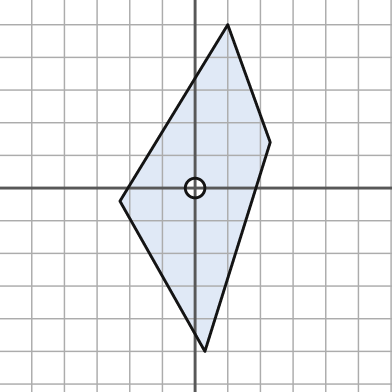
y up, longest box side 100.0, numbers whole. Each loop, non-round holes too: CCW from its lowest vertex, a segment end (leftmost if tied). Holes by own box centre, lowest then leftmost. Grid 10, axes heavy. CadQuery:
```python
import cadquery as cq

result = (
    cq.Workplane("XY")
    .moveTo(3.0, -50.0)
    .lineTo(23.0, 14.0)
    .lineTo(10.0, 50.0)
    .lineTo(-23.0, -4.0)
    .close()
    .moveTo(0.0, 0.0)
    .circle(3.0)
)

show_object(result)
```